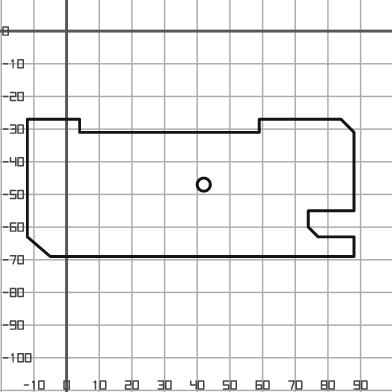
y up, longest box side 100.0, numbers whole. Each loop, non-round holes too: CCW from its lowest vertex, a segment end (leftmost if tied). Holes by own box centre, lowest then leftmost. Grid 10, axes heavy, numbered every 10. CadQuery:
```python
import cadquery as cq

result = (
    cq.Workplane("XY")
    .moveTo(-5.0, -69.0)
    .lineTo(88.0, -69.0)
    .lineTo(88.0, -63.0)
    .lineTo(77.0, -63.0)
    .lineTo(74.0, -60.0)
    .lineTo(74.0, -55.0)
    .lineTo(88.0, -55.0)
    .lineTo(88.0, -31.0)
    .lineTo(84.0, -27.0)
    .lineTo(59.0, -27.0)
    .lineTo(59.0, -31.0)
    .lineTo(4.0, -31.0)
    .lineTo(4.0, -27.0)
    .lineTo(-12.0, -27.0)
    .lineTo(-12.0, -63.0)
    .close()
    .moveTo(42.0, -47.0)
    .circle(2.0)
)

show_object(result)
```